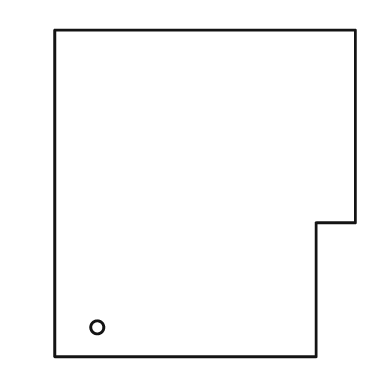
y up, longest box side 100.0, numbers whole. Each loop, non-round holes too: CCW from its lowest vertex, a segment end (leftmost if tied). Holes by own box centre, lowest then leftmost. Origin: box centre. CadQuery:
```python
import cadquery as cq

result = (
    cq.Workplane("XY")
    .moveTo(-46.0, -50.0)
    .lineTo(34.0, -50.0)
    .lineTo(34.0, -9.0)
    .lineTo(46.0, -9.0)
    .lineTo(46.0, 50.0)
    .lineTo(-46.0, 50.0)
    .close()
    .moveTo(-33.0, -41.0)
    .circle(2.0)
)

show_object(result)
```